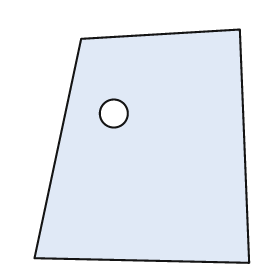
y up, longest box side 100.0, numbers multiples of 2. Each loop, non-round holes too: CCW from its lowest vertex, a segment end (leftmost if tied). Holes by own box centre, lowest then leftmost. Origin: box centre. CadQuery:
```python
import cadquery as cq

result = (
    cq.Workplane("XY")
    .moveTo(46.0, -50.0)
    .lineTo(42.0, 50.0)
    .lineTo(-26.0, 46.0)
    .lineTo(-46.0, -48.0)
    .close()
    .moveTo(-12.0, 14.0)
    .circle(6.0)
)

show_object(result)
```